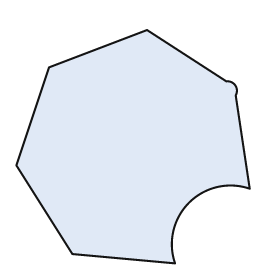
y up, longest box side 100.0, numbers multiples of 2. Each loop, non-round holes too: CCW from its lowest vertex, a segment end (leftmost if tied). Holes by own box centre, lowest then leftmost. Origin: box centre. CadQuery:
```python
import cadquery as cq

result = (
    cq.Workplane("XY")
    .moveTo(18.0, -50.0)
    .threePointArc((24.0, -24.0), (50.0, -18.0))
    .lineTo(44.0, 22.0)
    .threePointArc((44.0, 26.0), (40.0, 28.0))
    .lineTo(6.0, 50.0)
    .lineTo(-36.0, 34.0)
    .lineTo(-50.0, -8.0)
    .lineTo(-26.0, -46.0)
    .close()
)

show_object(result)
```